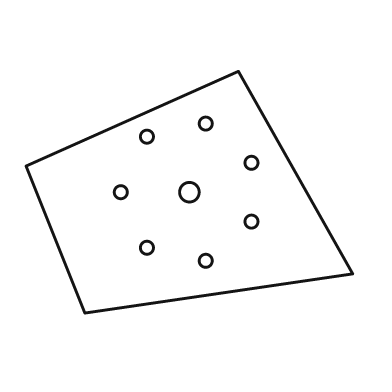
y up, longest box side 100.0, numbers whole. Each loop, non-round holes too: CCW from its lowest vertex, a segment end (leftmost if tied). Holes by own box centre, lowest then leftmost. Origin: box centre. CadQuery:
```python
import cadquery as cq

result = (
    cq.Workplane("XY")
    .moveTo(-32.0, -37.0)
    .lineTo(50.0, -25.0)
    .lineTo(15.0, 37.0)
    .lineTo(-50.0, 8.0)
    .close()
    .moveTo(5.0, -21.0)
    .circle(2.0)
    .moveTo(-13.0, -17.0)
    .circle(2.0)
    .moveTo(19.0, -9.0)
    .circle(2.0)
    .moveTo(-21.0, 0.0)
    .circle(2.0)
    .moveTo(0.0, 0.0)
    .circle(3.0)
    .moveTo(19.0, 9.0)
    .circle(2.0)
    .moveTo(-13.0, 17.0)
    .circle(2.0)
    .moveTo(5.0, 21.0)
    .circle(2.0)
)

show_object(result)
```